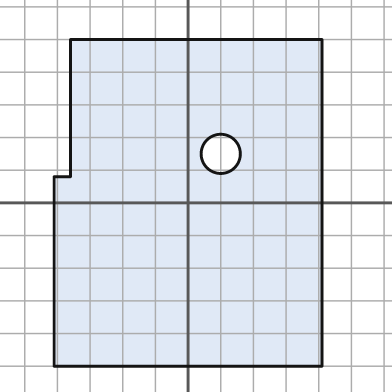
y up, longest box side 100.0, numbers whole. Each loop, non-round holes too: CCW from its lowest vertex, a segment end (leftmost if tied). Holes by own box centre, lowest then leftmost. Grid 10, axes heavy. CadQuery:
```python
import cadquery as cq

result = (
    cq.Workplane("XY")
    .moveTo(-41.0, -50.0)
    .lineTo(41.0, -50.0)
    .lineTo(41.0, 50.0)
    .lineTo(-36.0, 50.0)
    .lineTo(-36.0, 8.0)
    .lineTo(-41.0, 8.0)
    .close()
    .moveTo(10.0, 15.0)
    .circle(6.0)
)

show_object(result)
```